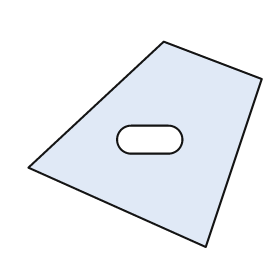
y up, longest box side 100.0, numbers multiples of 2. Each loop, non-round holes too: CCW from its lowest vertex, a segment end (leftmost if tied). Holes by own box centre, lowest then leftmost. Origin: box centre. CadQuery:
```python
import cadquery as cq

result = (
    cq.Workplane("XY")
    .moveTo(26.0, -44.0)
    .lineTo(50.0, 28.0)
    .lineTo(8.0, 44.0)
    .lineTo(-50.0, -10.0)
    .close()
    .moveTo(-6.0, -4.0)
    .lineTo(10.0, -4.0)
    .threePointArc((16.0, 2.0), (10.0, 8.0))
    .lineTo(-6.0, 8.0)
    .threePointArc((-12.0, 2.0), (-6.0, -4.0))
    .close()
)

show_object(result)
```